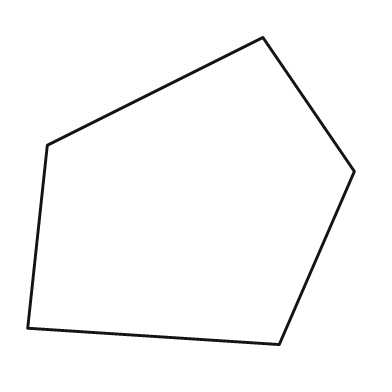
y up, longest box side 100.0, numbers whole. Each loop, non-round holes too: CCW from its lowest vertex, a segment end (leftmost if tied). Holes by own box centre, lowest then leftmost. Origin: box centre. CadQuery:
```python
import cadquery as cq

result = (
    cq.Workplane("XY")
    .moveTo(27.0, -47.0)
    .lineTo(50.0, 6.0)
    .lineTo(22.0, 47.0)
    .lineTo(-44.0, 14.0)
    .lineTo(-50.0, -42.0)
    .close()
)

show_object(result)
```